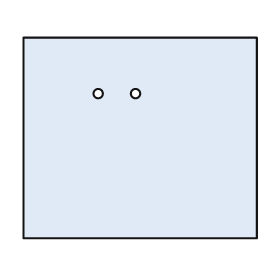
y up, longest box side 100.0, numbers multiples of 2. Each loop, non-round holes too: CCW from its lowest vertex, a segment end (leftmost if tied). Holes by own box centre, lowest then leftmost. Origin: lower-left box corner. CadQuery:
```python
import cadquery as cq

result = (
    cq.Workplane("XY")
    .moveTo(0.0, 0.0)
    .lineTo(100.0, 0.0)
    .lineTo(100.0, 86.0)
    .lineTo(0.0, 86.0)
    .close()
    .moveTo(32.0, 62.0)
    .circle(2.0)
    .moveTo(48.0, 62.0)
    .circle(2.0)
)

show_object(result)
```